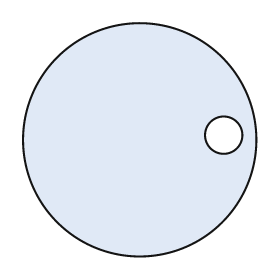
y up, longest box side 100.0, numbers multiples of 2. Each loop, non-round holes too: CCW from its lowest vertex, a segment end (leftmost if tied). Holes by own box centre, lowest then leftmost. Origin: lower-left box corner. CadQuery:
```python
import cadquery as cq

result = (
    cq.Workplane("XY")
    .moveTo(50.0, 50.0)
    .circle(50.0)
    .moveTo(86.0, 52.0)
    .circle(8.0)
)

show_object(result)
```